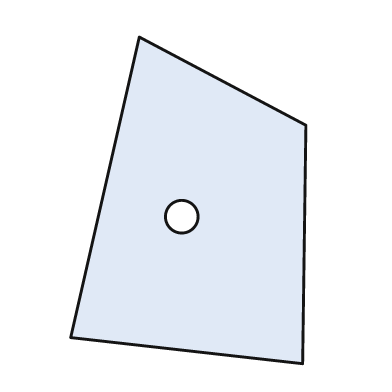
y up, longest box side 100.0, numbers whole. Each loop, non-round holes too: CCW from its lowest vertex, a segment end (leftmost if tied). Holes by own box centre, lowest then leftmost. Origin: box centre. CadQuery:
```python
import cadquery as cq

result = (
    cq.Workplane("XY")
    .moveTo(35.0, -50.0)
    .lineTo(36.0, 23.0)
    .lineTo(-15.0, 50.0)
    .lineTo(-36.0, -42.0)
    .close()
    .moveTo(-2.0, -5.0)
    .circle(5.0)
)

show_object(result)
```